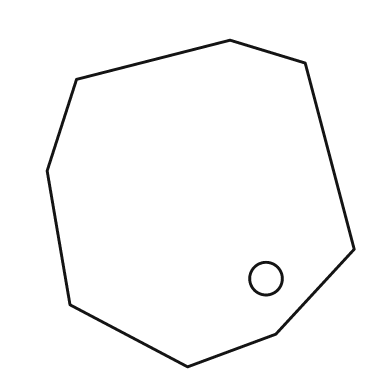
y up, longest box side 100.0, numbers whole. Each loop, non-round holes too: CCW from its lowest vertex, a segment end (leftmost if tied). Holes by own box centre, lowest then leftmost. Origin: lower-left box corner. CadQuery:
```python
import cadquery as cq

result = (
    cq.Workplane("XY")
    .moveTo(43.0, 0.0)
    .lineTo(70.0, 10.0)
    .lineTo(94.0, 36.0)
    .lineTo(79.0, 93.0)
    .lineTo(56.0, 100.0)
    .lineTo(9.0, 88.0)
    .lineTo(0.0, 60.0)
    .lineTo(7.0, 19.0)
    .close()
    .moveTo(67.0, 27.0)
    .circle(5.0)
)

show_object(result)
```